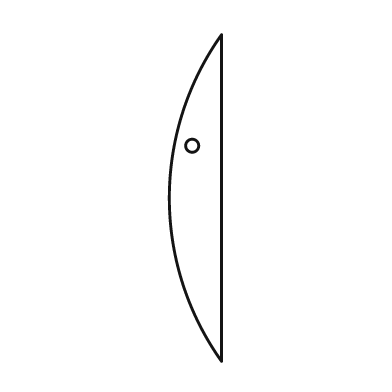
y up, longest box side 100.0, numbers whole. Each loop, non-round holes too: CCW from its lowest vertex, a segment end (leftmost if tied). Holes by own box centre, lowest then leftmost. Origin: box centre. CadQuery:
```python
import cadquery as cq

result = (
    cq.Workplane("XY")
    .moveTo(8.0, -50.0)
    .lineTo(8.0, 50.0)
    .threePointArc((-8.0, 0.0), (8.0, -50.0))
    .close()
    .moveTo(-1.0, 16.0)
    .circle(2.0)
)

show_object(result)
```